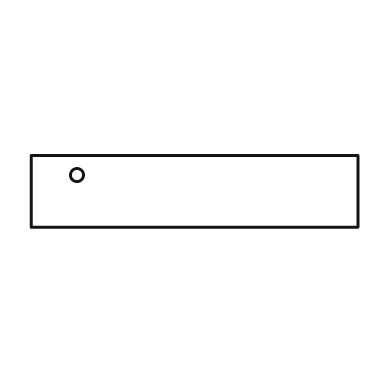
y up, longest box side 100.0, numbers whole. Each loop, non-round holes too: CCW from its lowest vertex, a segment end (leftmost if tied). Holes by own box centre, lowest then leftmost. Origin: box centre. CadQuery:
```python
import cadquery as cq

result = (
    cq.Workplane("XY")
    .moveTo(-50.0, -11.0)
    .lineTo(50.0, -11.0)
    .lineTo(50.0, 11.0)
    .lineTo(-50.0, 11.0)
    .close()
    .moveTo(-36.0, 5.0)
    .circle(2.0)
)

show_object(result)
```